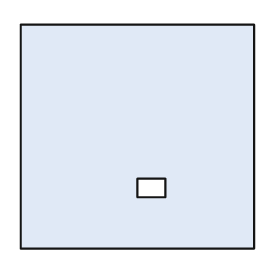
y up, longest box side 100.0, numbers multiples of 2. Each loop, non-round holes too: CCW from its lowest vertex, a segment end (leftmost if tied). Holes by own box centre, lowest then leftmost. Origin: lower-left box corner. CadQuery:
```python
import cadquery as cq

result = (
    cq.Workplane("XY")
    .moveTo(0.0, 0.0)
    .lineTo(100.0, 0.0)
    .lineTo(100.0, 96.0)
    .lineTo(0.0, 96.0)
    .close()
    .moveTo(50.0, 22.0)
    .lineTo(62.0, 22.0)
    .lineTo(62.0, 30.0)
    .lineTo(50.0, 30.0)
    .close()
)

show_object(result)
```